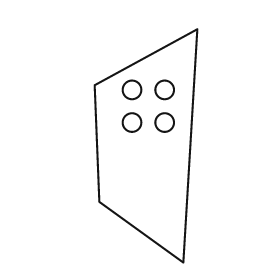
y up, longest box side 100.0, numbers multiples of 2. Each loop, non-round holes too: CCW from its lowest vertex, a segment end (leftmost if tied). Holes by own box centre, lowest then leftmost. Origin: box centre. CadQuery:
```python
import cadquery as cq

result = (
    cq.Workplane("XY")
    .moveTo(16.0, -50.0)
    .lineTo(22.0, 50.0)
    .lineTo(-22.0, 26.0)
    .lineTo(-20.0, -24.0)
    .close()
    .moveTo(-6.0, 10.0)
    .circle(4.0)
    .moveTo(8.0, 10.0)
    .circle(4.0)
    .moveTo(-6.0, 24.0)
    .circle(4.0)
    .moveTo(8.0, 24.0)
    .circle(4.0)
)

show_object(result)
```